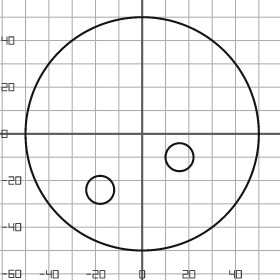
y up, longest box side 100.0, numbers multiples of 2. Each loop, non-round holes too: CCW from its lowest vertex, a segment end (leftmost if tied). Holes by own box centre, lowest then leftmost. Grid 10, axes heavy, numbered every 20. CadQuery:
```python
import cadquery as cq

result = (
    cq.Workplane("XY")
    .moveTo(0.0, 0.0)
    .circle(50.0)
    .moveTo(-18.0, -24.0)
    .circle(6.0)
    .moveTo(16.0, -10.0)
    .circle(6.0)
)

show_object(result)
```